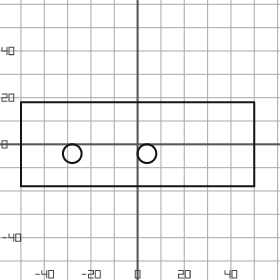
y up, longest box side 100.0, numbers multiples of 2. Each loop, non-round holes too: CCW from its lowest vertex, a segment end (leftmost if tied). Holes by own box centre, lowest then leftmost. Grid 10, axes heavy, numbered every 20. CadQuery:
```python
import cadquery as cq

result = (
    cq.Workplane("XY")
    .moveTo(-50.0, -18.0)
    .lineTo(50.0, -18.0)
    .lineTo(50.0, 18.0)
    .lineTo(-50.0, 18.0)
    .close()
    .moveTo(-28.0, -4.0)
    .circle(4.0)
    .moveTo(4.0, -4.0)
    .circle(4.0)
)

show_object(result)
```